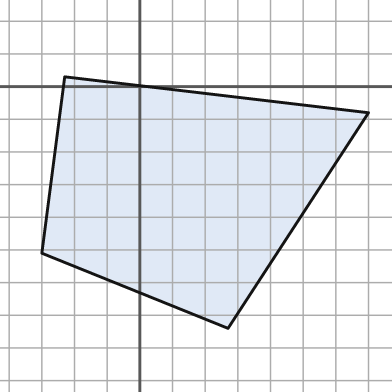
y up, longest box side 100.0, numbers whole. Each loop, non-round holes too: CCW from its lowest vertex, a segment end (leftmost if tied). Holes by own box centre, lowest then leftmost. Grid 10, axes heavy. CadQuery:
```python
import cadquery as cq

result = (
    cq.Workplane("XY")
    .moveTo(27.0, -74.0)
    .lineTo(70.0, -8.0)
    .lineTo(-23.0, 3.0)
    .lineTo(-30.0, -51.0)
    .close()
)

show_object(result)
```